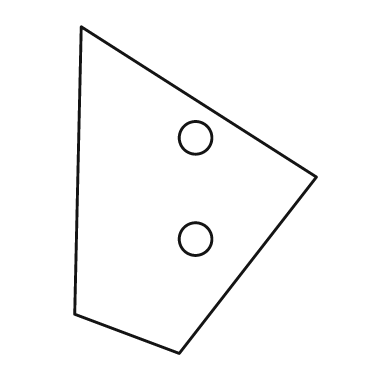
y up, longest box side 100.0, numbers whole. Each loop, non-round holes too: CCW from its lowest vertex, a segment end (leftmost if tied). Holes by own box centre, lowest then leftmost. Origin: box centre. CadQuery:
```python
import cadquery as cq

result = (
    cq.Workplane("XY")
    .moveTo(-5.0, -50.0)
    .lineTo(37.0, 4.0)
    .lineTo(-35.0, 50.0)
    .lineTo(-37.0, -38.0)
    .close()
    .moveTo(0.0, -15.0)
    .circle(5.0)
    .moveTo(0.0, 16.0)
    .circle(5.0)
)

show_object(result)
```